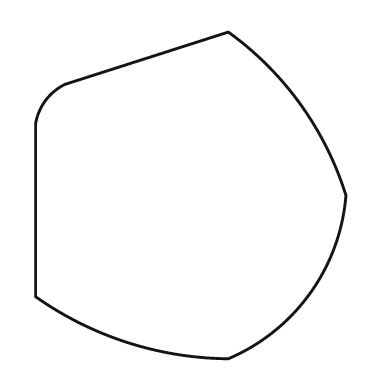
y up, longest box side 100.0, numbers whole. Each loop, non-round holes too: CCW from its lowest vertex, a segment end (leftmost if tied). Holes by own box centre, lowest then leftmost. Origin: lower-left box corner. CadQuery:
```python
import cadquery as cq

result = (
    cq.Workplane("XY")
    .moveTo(59.0, 0.0)
    .threePointArc((84.0, 20.0), (95.0, 50.0))
    .threePointArc((81.0, 78.0), (59.0, 100.0))
    .lineTo(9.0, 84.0)
    .threePointArc((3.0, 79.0), (0.0, 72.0))
    .lineTo(0.0, 19.0)
    .threePointArc((28.0, 5.0), (59.0, 0.0))
    .close()
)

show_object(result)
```